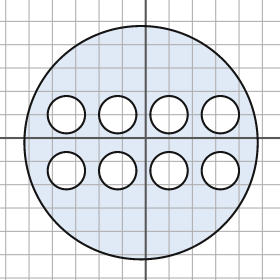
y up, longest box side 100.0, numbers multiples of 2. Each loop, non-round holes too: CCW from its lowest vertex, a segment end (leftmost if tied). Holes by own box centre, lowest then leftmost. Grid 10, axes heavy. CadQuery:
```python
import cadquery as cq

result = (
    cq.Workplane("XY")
    .moveTo(-2.0, -2.0)
    .circle(50.0)
    .moveTo(-34.0, -14.0)
    .circle(8.0)
    .moveTo(-12.0, -14.0)
    .circle(8.0)
    .moveTo(10.0, -14.0)
    .circle(8.0)
    .moveTo(32.0, -14.0)
    .circle(8.0)
    .moveTo(-34.0, 10.0)
    .circle(8.0)
    .moveTo(-12.0, 10.0)
    .circle(8.0)
    .moveTo(10.0, 10.0)
    .circle(8.0)
    .moveTo(32.0, 10.0)
    .circle(8.0)
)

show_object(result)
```